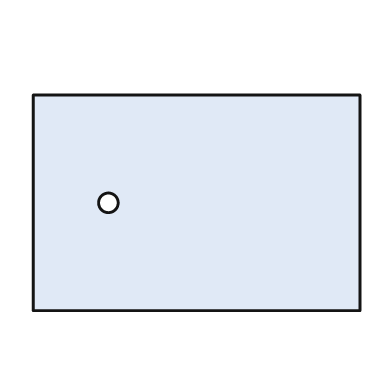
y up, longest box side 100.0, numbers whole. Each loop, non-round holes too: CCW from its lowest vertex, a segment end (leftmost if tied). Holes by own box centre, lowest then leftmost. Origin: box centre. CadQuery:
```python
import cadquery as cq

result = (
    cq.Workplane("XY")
    .moveTo(-50.0, -33.0)
    .lineTo(50.0, -33.0)
    .lineTo(50.0, 33.0)
    .lineTo(-50.0, 33.0)
    .close()
    .moveTo(-27.0, 0.0)
    .circle(3.0)
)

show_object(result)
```